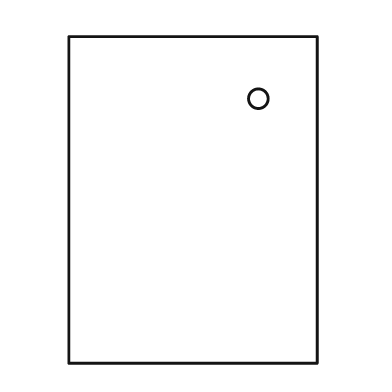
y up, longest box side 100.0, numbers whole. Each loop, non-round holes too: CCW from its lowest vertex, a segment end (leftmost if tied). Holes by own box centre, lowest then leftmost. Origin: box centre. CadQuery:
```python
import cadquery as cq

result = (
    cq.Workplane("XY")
    .moveTo(-38.0, -50.0)
    .lineTo(38.0, -50.0)
    .lineTo(38.0, 50.0)
    .lineTo(-38.0, 50.0)
    .close()
    .moveTo(20.0, 31.0)
    .circle(3.0)
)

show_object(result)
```